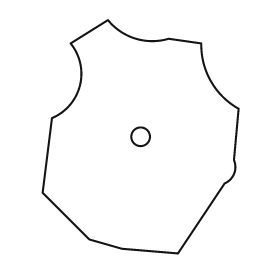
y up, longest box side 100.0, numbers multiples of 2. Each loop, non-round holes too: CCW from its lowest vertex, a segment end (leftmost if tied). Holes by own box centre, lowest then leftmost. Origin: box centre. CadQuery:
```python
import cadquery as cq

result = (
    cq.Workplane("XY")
    .moveTo(16.0, -50.0)
    .lineTo(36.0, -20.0)
    .threePointArc((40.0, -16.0), (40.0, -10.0))
    .lineTo(42.0, 12.0)
    .threePointArc((30.0, 24.0), (26.0, 40.0))
    .lineTo(12.0, 42.0)
    .threePointArc((-2.0, 42.0), (-14.0, 50.0))
    .lineTo(-30.0, 40.0)
    .threePointArc((-26.0, 22.0), (-38.0, 8.0))
    .lineTo(-42.0, -24.0)
    .lineTo(-22.0, -44.0)
    .lineTo(-8.0, -48.0)
    .close()
    .moveTo(0.0, 0.0)
    .circle(4.0)
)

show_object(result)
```